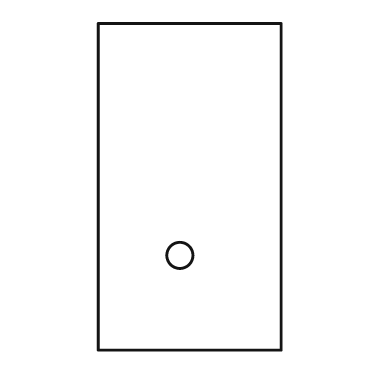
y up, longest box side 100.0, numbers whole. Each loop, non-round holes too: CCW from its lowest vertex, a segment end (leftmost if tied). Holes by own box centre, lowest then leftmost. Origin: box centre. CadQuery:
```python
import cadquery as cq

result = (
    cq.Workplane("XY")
    .moveTo(-28.0, -50.0)
    .lineTo(28.0, -50.0)
    .lineTo(28.0, 50.0)
    .lineTo(-28.0, 50.0)
    .close()
    .moveTo(-3.0, -21.0)
    .circle(4.0)
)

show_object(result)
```